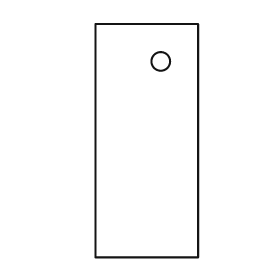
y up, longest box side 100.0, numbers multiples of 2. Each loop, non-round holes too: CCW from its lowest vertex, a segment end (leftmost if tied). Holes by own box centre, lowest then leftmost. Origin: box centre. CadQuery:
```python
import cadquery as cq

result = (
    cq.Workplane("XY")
    .moveTo(-22.0, -50.0)
    .lineTo(22.0, -50.0)
    .lineTo(22.0, 50.0)
    .lineTo(-22.0, 50.0)
    .close()
    .moveTo(6.0, 34.0)
    .circle(4.0)
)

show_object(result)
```